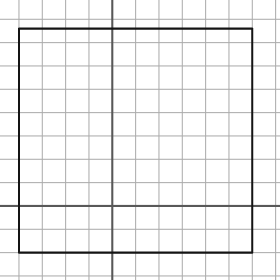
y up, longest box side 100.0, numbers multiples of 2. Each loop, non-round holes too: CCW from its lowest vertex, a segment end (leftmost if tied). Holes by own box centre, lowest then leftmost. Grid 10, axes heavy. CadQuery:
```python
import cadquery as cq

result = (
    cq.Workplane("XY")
    .moveTo(-40.0, -20.0)
    .lineTo(60.0, -20.0)
    .lineTo(60.0, 76.0)
    .lineTo(-40.0, 76.0)
    .close()
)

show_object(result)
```